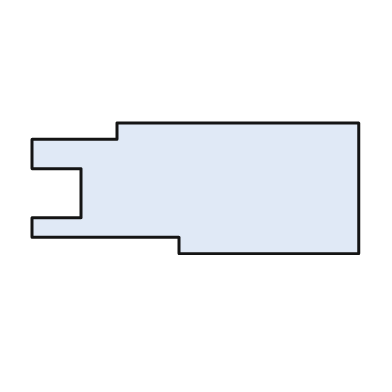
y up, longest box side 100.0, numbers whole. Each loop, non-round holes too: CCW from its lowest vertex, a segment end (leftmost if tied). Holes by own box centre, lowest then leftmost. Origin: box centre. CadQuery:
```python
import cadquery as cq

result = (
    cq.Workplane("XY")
    .moveTo(-5.0, -20.0)
    .lineTo(50.0, -20.0)
    .lineTo(50.0, 20.0)
    .lineTo(-24.0, 20.0)
    .lineTo(-24.0, 15.0)
    .lineTo(-50.0, 15.0)
    .lineTo(-50.0, 6.0)
    .lineTo(-35.0, 6.0)
    .lineTo(-35.0, -9.0)
    .lineTo(-50.0, -9.0)
    .lineTo(-50.0, -15.0)
    .lineTo(-5.0, -15.0)
    .close()
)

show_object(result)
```